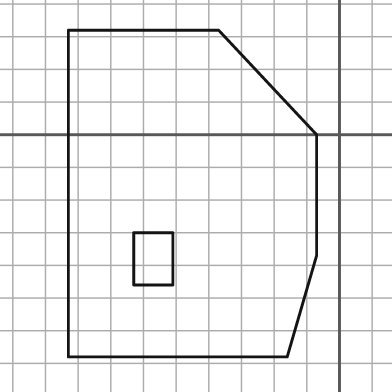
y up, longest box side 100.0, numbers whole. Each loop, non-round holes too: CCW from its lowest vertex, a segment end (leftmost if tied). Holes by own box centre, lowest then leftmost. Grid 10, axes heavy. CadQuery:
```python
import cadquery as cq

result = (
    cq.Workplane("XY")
    .moveTo(-83.0, -68.0)
    .lineTo(-16.0, -68.0)
    .lineTo(-7.0, -37.0)
    .lineTo(-7.0, 0.0)
    .lineTo(-37.0, 32.0)
    .lineTo(-83.0, 32.0)
    .close()
    .moveTo(-63.0, -46.0)
    .lineTo(-51.0, -46.0)
    .lineTo(-51.0, -30.0)
    .lineTo(-63.0, -30.0)
    .close()
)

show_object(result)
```